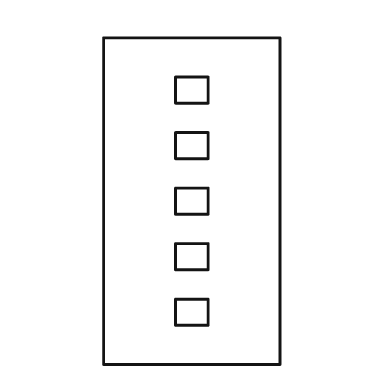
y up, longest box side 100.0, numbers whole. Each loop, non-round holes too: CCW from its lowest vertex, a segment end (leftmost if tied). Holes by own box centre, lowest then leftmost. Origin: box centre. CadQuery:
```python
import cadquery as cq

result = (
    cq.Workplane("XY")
    .moveTo(-27.0, -50.0)
    .lineTo(27.0, -50.0)
    .lineTo(27.0, 50.0)
    .lineTo(-27.0, 50.0)
    .close()
    .moveTo(-5.0, -38.0)
    .lineTo(5.0, -38.0)
    .lineTo(5.0, -30.0)
    .lineTo(-5.0, -30.0)
    .close()
    .moveTo(-5.0, -21.0)
    .lineTo(5.0, -21.0)
    .lineTo(5.0, -13.0)
    .lineTo(-5.0, -13.0)
    .close()
    .moveTo(-5.0, -4.0)
    .lineTo(5.0, -4.0)
    .lineTo(5.0, 4.0)
    .lineTo(-5.0, 4.0)
    .close()
    .moveTo(-5.0, 13.0)
    .lineTo(5.0, 13.0)
    .lineTo(5.0, 21.0)
    .lineTo(-5.0, 21.0)
    .close()
    .moveTo(-5.0, 30.0)
    .lineTo(5.0, 30.0)
    .lineTo(5.0, 38.0)
    .lineTo(-5.0, 38.0)
    .close()
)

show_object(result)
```